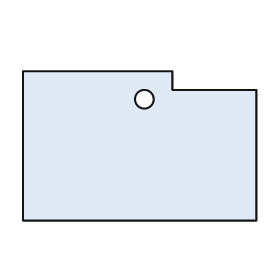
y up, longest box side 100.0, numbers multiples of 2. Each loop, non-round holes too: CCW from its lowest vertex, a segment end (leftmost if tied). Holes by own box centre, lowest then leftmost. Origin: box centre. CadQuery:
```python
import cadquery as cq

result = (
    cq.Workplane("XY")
    .moveTo(-50.0, -32.0)
    .lineTo(50.0, -32.0)
    .lineTo(50.0, 24.0)
    .lineTo(14.0, 24.0)
    .lineTo(14.0, 32.0)
    .lineTo(-50.0, 32.0)
    .close()
    .moveTo(2.0, 20.0)
    .circle(4.0)
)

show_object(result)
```